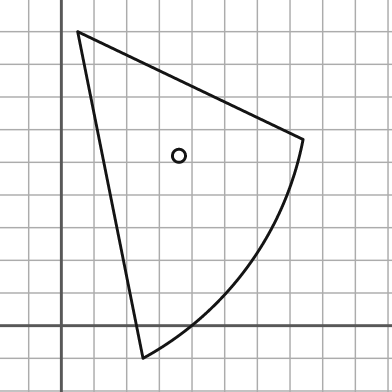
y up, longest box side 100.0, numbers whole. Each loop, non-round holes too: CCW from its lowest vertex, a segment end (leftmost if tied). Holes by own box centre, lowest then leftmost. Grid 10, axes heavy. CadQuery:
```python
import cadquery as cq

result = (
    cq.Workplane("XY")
    .moveTo(25.0, -10.0)
    .threePointArc((57.0, 18.0), (74.0, 57.0))
    .lineTo(5.0, 90.0)
    .close()
    .moveTo(36.0, 52.0)
    .circle(2.0)
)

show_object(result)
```